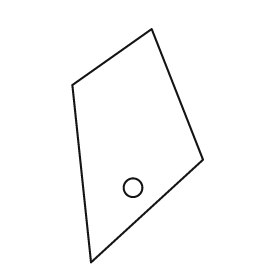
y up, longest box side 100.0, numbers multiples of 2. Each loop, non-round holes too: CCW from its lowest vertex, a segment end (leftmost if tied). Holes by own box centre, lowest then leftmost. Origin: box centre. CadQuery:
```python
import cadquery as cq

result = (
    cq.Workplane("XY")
    .moveTo(-20.0, -50.0)
    .lineTo(28.0, -6.0)
    .lineTo(6.0, 50.0)
    .lineTo(-28.0, 26.0)
    .close()
    .moveTo(-2.0, -18.0)
    .circle(4.0)
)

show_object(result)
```